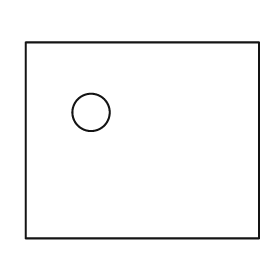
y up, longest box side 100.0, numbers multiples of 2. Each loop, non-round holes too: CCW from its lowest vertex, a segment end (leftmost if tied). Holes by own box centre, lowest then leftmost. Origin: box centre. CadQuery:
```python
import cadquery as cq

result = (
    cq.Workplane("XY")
    .moveTo(-50.0, -42.0)
    .lineTo(50.0, -42.0)
    .lineTo(50.0, 42.0)
    .lineTo(-50.0, 42.0)
    .close()
    .moveTo(-22.0, 12.0)
    .circle(8.0)
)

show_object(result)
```